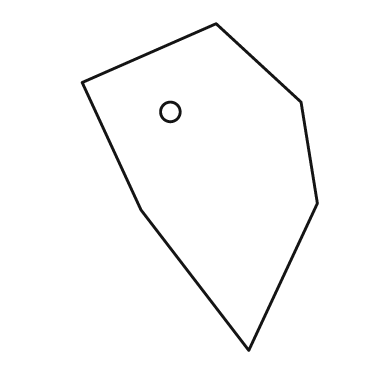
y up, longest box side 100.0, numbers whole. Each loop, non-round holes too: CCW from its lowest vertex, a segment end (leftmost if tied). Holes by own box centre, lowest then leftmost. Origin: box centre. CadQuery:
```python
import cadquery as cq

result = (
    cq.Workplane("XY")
    .moveTo(15.0, -50.0)
    .lineTo(36.0, -5.0)
    .lineTo(31.0, 26.0)
    .lineTo(5.0, 50.0)
    .lineTo(-36.0, 32.0)
    .lineTo(-18.0, -7.0)
    .close()
    .moveTo(-9.0, 23.0)
    .circle(3.0)
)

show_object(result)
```